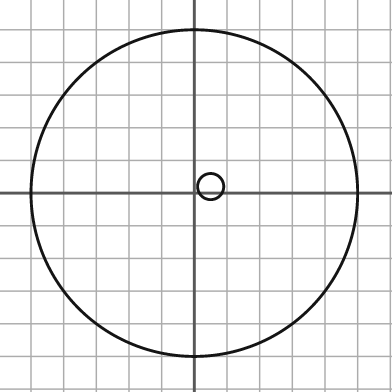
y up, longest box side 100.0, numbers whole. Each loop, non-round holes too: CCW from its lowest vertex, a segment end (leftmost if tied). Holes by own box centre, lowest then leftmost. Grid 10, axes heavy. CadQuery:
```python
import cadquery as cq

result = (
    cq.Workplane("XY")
    .moveTo(0.0, 0.0)
    .circle(50.0)
    .moveTo(5.0, 2.0)
    .circle(4.0)
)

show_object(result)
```